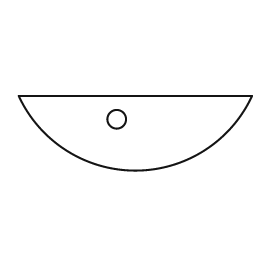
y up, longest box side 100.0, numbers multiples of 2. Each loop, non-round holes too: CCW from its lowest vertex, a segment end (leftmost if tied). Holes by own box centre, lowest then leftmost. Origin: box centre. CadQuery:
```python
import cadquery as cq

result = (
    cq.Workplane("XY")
    .moveTo(-50.0, 16.0)
    .threePointArc((0.0, -16.0), (50.0, 16.0))
    .close()
    .moveTo(-8.0, 6.0)
    .circle(4.0)
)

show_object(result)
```